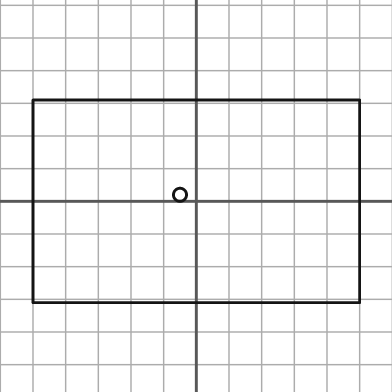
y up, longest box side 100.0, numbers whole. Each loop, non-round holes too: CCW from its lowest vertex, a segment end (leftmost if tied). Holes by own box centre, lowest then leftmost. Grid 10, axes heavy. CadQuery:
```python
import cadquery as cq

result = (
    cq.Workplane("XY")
    .moveTo(-50.0, -31.0)
    .lineTo(50.0, -31.0)
    .lineTo(50.0, 31.0)
    .lineTo(-50.0, 31.0)
    .close()
    .moveTo(-5.0, 2.0)
    .circle(2.0)
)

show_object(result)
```